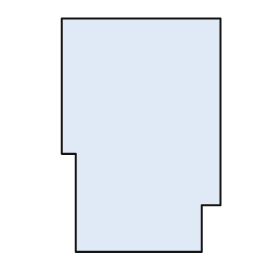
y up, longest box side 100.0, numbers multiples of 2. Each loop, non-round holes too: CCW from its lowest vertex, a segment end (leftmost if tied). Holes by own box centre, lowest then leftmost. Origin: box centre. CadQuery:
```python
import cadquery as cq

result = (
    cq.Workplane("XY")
    .moveTo(-28.0, -50.0)
    .lineTo(26.0, -50.0)
    .lineTo(26.0, -30.0)
    .lineTo(34.0, -30.0)
    .lineTo(34.0, 50.0)
    .lineTo(-34.0, 50.0)
    .lineTo(-34.0, -8.0)
    .lineTo(-28.0, -8.0)
    .close()
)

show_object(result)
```